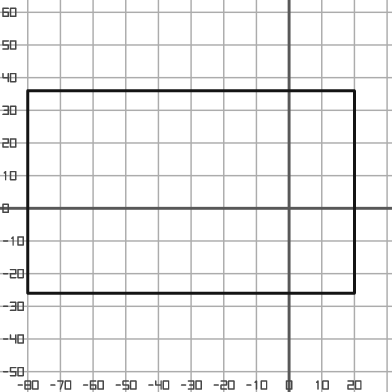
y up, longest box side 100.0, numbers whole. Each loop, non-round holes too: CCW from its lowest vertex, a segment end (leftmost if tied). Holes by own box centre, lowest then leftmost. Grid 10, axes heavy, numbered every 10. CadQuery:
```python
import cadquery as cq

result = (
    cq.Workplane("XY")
    .moveTo(-80.0, -26.0)
    .lineTo(20.0, -26.0)
    .lineTo(20.0, 36.0)
    .lineTo(-80.0, 36.0)
    .close()
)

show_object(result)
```